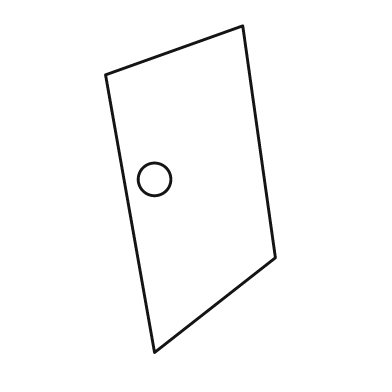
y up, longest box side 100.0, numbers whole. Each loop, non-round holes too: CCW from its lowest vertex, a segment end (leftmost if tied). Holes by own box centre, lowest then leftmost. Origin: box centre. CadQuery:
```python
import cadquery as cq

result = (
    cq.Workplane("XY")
    .moveTo(-11.0, -50.0)
    .lineTo(26.0, -21.0)
    .lineTo(16.0, 50.0)
    .lineTo(-26.0, 35.0)
    .close()
    .moveTo(-11.0, 3.0)
    .circle(5.0)
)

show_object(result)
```